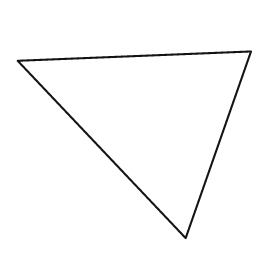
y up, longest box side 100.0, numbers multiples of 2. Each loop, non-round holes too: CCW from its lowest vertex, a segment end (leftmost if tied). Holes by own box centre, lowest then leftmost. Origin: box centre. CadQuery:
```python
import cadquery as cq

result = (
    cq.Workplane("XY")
    .moveTo(22.0, -40.0)
    .lineTo(50.0, 40.0)
    .lineTo(-50.0, 36.0)
    .close()
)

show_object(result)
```